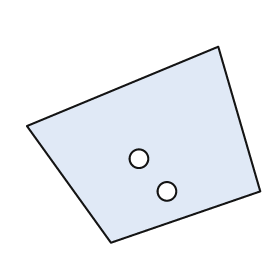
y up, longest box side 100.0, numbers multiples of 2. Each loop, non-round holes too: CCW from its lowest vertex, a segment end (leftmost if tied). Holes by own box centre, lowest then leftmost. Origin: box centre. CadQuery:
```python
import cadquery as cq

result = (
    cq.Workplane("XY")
    .moveTo(-14.0, -42.0)
    .lineTo(50.0, -20.0)
    .lineTo(32.0, 42.0)
    .lineTo(-50.0, 8.0)
    .close()
    .moveTo(10.0, -20.0)
    .circle(4.0)
    .moveTo(-2.0, -6.0)
    .circle(4.0)
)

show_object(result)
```